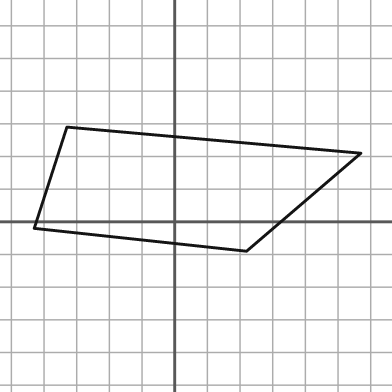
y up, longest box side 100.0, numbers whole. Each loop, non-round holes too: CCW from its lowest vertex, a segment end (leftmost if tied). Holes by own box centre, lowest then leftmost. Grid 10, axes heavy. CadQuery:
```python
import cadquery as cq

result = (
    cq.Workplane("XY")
    .moveTo(22.0, -9.0)
    .lineTo(57.0, 21.0)
    .lineTo(-33.0, 29.0)
    .lineTo(-43.0, -2.0)
    .close()
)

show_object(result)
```